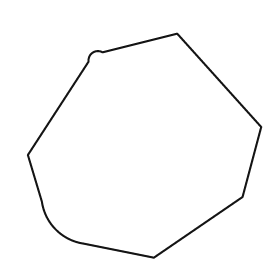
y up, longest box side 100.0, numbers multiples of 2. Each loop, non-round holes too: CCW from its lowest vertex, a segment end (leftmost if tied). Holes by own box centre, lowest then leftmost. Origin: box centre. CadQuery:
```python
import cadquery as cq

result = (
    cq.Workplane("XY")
    .moveTo(4.0, -48.0)
    .lineTo(42.0, -22.0)
    .lineTo(50.0, 8.0)
    .lineTo(14.0, 48.0)
    .lineTo(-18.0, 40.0)
    .threePointArc((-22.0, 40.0), (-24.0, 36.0))
    .lineTo(-50.0, -4.0)
    .lineTo(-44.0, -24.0)
    .threePointArc((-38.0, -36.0), (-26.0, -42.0))
    .close()
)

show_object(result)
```